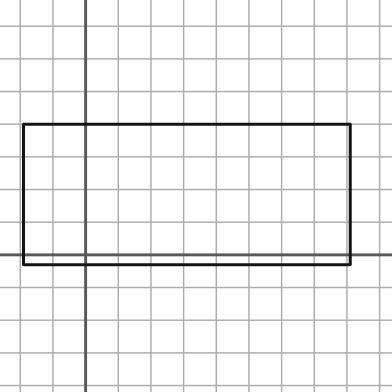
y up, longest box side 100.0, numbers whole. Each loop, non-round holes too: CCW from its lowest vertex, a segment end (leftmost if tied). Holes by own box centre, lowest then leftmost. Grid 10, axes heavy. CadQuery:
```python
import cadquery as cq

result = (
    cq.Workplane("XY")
    .moveTo(-19.0, -3.0)
    .lineTo(81.0, -3.0)
    .lineTo(81.0, 40.0)
    .lineTo(-19.0, 40.0)
    .close()
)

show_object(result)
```